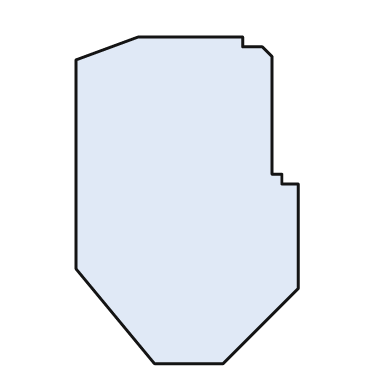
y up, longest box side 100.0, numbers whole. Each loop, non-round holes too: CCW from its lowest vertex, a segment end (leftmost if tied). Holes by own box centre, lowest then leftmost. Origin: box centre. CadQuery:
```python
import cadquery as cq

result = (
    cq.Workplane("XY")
    .moveTo(-10.0, -50.0)
    .lineTo(11.0, -50.0)
    .lineTo(34.0, -27.0)
    .lineTo(34.0, 5.0)
    .lineTo(29.0, 5.0)
    .lineTo(29.0, 8.0)
    .lineTo(26.0, 8.0)
    .lineTo(26.0, 44.0)
    .lineTo(23.0, 47.0)
    .lineTo(17.0, 47.0)
    .lineTo(17.0, 50.0)
    .lineTo(-15.0, 50.0)
    .lineTo(-34.0, 43.0)
    .lineTo(-34.0, -21.0)
    .close()
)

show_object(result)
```